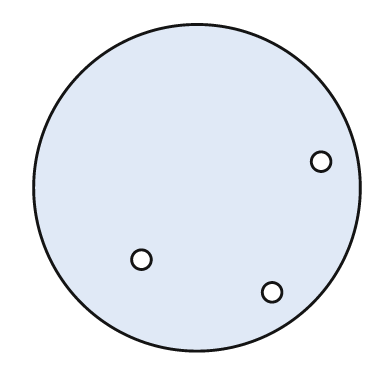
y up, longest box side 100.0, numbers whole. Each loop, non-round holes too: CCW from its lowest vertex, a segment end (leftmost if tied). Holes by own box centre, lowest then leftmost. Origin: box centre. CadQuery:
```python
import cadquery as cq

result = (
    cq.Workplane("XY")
    .moveTo(0.0, 0.0)
    .circle(50.0)
    .moveTo(23.0, -32.0)
    .circle(3.0)
    .moveTo(-17.0, -22.0)
    .circle(3.0)
    .moveTo(38.0, 8.0)
    .circle(3.0)
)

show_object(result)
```